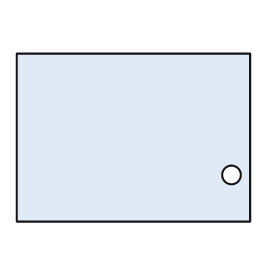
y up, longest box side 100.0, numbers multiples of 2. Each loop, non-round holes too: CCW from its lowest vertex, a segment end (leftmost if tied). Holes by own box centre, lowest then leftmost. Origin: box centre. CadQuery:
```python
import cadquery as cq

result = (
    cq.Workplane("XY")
    .moveTo(-50.0, -36.0)
    .lineTo(50.0, -36.0)
    .lineTo(50.0, 36.0)
    .lineTo(-50.0, 36.0)
    .close()
    .moveTo(42.0, -16.0)
    .circle(4.0)
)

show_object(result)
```